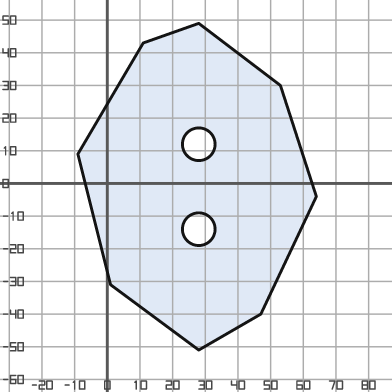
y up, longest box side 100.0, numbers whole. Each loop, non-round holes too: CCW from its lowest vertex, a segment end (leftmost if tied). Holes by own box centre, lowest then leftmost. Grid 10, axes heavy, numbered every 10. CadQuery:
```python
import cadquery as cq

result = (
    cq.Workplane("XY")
    .moveTo(28.0, -51.0)
    .lineTo(47.0, -40.0)
    .lineTo(64.0, -4.0)
    .lineTo(53.0, 30.0)
    .lineTo(28.0, 49.0)
    .lineTo(11.0, 43.0)
    .lineTo(-9.0, 9.0)
    .lineTo(1.0, -31.0)
    .close()
    .moveTo(28.0, -14.0)
    .circle(5.0)
    .moveTo(28.0, 12.0)
    .circle(5.0)
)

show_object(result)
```